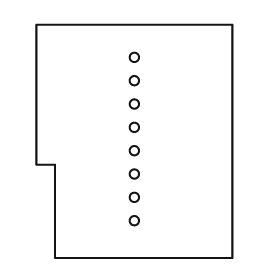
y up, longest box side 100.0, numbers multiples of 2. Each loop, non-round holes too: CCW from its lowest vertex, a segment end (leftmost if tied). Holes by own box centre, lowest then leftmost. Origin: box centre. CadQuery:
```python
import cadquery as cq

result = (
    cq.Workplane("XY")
    .moveTo(-34.0, -50.0)
    .lineTo(42.0, -50.0)
    .lineTo(42.0, 50.0)
    .lineTo(-42.0, 50.0)
    .lineTo(-42.0, -10.0)
    .lineTo(-34.0, -10.0)
    .close()
    .moveTo(0.0, -34.0)
    .circle(2.0)
    .moveTo(0.0, -24.0)
    .circle(2.0)
    .moveTo(0.0, -14.0)
    .circle(2.0)
    .moveTo(0.0, -4.0)
    .circle(2.0)
    .moveTo(0.0, 6.0)
    .circle(2.0)
    .moveTo(0.0, 16.0)
    .circle(2.0)
    .moveTo(0.0, 26.0)
    .circle(2.0)
    .moveTo(0.0, 36.0)
    .circle(2.0)
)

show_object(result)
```